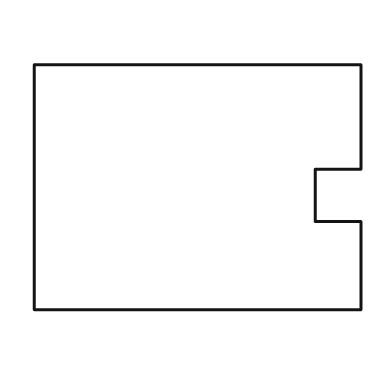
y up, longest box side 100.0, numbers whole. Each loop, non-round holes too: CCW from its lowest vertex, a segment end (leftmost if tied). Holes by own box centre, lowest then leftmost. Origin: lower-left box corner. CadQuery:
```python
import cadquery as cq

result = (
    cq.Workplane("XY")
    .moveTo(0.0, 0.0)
    .lineTo(100.0, 0.0)
    .lineTo(100.0, 27.0)
    .lineTo(86.0, 27.0)
    .lineTo(86.0, 43.0)
    .lineTo(100.0, 43.0)
    .lineTo(100.0, 75.0)
    .lineTo(0.0, 75.0)
    .close()
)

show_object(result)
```